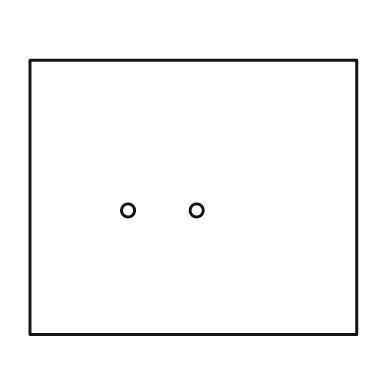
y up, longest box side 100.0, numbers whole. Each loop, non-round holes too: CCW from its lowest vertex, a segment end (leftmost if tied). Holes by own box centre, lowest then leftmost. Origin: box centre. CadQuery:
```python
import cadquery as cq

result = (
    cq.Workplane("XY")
    .moveTo(-50.0, -42.0)
    .lineTo(50.0, -42.0)
    .lineTo(50.0, 42.0)
    .lineTo(-50.0, 42.0)
    .close()
    .moveTo(-20.0, -4.0)
    .circle(2.0)
    .moveTo(1.0, -4.0)
    .circle(2.0)
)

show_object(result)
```